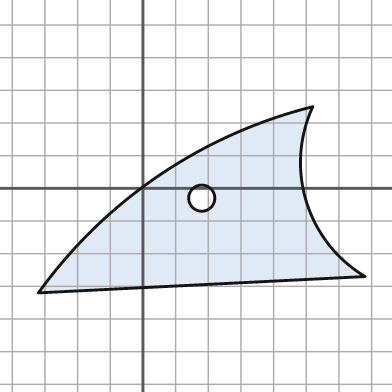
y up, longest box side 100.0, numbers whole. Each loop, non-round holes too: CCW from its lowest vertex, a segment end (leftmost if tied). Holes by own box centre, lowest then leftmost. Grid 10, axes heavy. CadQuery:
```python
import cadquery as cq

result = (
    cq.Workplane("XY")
    .moveTo(-32.0, -32.0)
    .lineTo(68.0, -27.0)
    .threePointArc((50.0, -4.0), (52.0, 25.0))
    .threePointArc((5.0, 4.0), (-32.0, -32.0))
    .close()
    .moveTo(18.0, -3.0)
    .circle(4.0)
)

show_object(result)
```